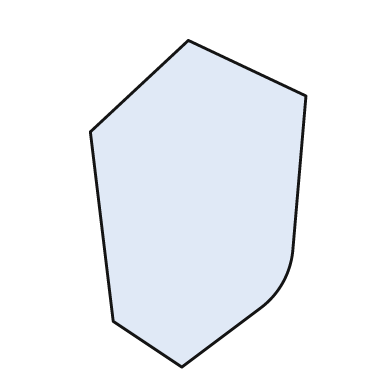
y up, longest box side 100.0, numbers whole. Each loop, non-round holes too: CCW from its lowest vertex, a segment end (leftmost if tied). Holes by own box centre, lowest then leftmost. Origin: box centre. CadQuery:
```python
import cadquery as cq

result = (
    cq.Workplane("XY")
    .moveTo(-5.0, -50.0)
    .lineTo(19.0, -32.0)
    .threePointArc((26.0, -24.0), (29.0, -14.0))
    .lineTo(33.0, 33.0)
    .lineTo(-3.0, 50.0)
    .lineTo(-33.0, 22.0)
    .lineTo(-26.0, -36.0)
    .close()
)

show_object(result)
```